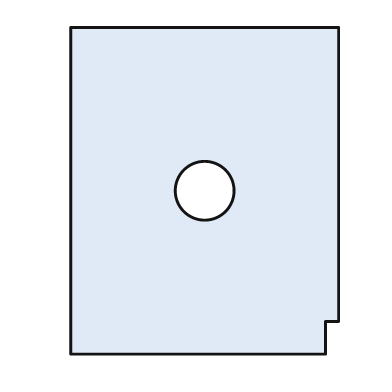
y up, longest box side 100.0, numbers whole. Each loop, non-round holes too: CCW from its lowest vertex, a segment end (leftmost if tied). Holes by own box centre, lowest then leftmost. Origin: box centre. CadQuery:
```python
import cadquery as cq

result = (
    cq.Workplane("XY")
    .moveTo(-41.0, -50.0)
    .lineTo(37.0, -50.0)
    .lineTo(37.0, -40.0)
    .lineTo(41.0, -40.0)
    .lineTo(41.0, 50.0)
    .lineTo(-41.0, 50.0)
    .close()
    .moveTo(0.0, 0.0)
    .circle(9.0)
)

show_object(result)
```